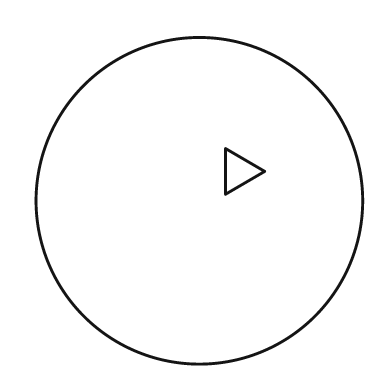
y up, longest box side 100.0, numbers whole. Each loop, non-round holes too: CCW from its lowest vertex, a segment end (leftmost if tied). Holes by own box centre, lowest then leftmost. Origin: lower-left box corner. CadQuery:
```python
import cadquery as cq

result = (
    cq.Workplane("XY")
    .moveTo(50.0, 50.0)
    .circle(50.0)
    .moveTo(58.0, 52.0)
    .lineTo(70.0, 59.0)
    .lineTo(58.0, 66.0)
    .close()
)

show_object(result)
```